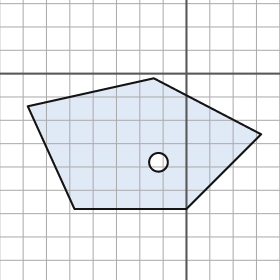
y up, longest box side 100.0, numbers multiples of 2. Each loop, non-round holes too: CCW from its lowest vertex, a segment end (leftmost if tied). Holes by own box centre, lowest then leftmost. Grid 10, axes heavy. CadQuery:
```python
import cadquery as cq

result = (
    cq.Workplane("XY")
    .moveTo(-48.0, -58.0)
    .lineTo(0.0, -58.0)
    .lineTo(32.0, -26.0)
    .lineTo(-14.0, -2.0)
    .lineTo(-68.0, -14.0)
    .close()
    .moveTo(-12.0, -38.0)
    .circle(4.0)
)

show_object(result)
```